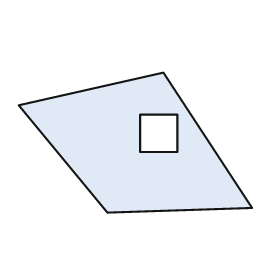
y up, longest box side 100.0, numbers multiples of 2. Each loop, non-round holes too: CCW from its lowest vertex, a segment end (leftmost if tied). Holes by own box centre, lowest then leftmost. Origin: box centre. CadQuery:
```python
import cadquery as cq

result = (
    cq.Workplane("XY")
    .moveTo(-12.0, -30.0)
    .lineTo(50.0, -28.0)
    .lineTo(12.0, 30.0)
    .lineTo(-50.0, 16.0)
    .close()
    .moveTo(2.0, -4.0)
    .lineTo(18.0, -4.0)
    .lineTo(18.0, 12.0)
    .lineTo(2.0, 12.0)
    .close()
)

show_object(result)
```